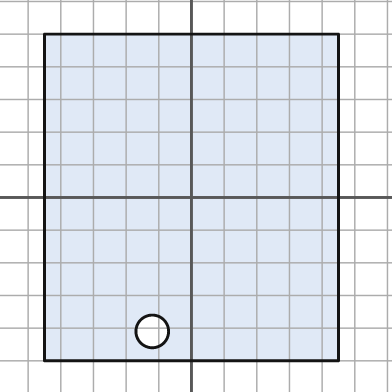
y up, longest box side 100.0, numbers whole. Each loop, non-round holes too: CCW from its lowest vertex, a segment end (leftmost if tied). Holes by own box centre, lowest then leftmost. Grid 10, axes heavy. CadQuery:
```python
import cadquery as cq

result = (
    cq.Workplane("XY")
    .moveTo(-45.0, -50.0)
    .lineTo(45.0, -50.0)
    .lineTo(45.0, 50.0)
    .lineTo(-45.0, 50.0)
    .close()
    .moveTo(-12.0, -41.0)
    .circle(5.0)
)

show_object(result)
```